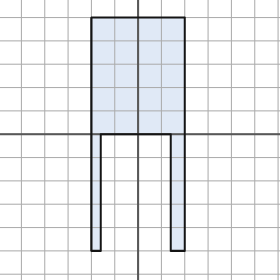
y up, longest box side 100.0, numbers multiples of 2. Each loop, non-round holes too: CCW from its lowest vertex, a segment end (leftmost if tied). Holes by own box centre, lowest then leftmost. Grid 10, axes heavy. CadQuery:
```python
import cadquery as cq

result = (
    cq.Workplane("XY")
    .moveTo(-20.0, -50.0)
    .lineTo(-16.0, -50.0)
    .lineTo(-16.0, 0.0)
    .lineTo(14.0, 0.0)
    .lineTo(14.0, -50.0)
    .lineTo(20.0, -50.0)
    .lineTo(20.0, 50.0)
    .lineTo(-20.0, 50.0)
    .close()
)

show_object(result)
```